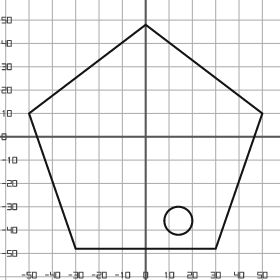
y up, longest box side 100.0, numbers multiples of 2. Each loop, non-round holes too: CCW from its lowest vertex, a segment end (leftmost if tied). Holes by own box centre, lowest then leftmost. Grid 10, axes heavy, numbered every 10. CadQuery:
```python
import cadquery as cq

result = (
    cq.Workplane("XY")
    .moveTo(-30.0, -48.0)
    .lineTo(30.0, -48.0)
    .lineTo(50.0, 10.0)
    .lineTo(0.0, 48.0)
    .lineTo(-50.0, 10.0)
    .close()
    .moveTo(14.0, -36.0)
    .circle(6.0)
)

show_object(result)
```